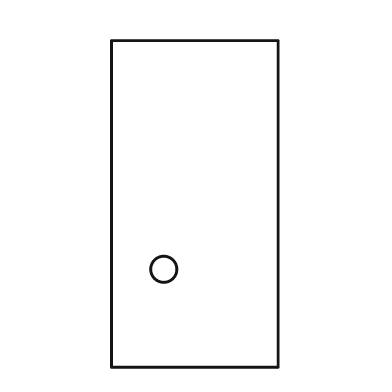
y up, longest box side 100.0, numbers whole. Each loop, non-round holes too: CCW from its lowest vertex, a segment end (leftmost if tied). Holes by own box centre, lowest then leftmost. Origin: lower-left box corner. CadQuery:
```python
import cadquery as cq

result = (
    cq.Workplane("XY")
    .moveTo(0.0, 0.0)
    .lineTo(51.0, 0.0)
    .lineTo(51.0, 100.0)
    .lineTo(0.0, 100.0)
    .close()
    .moveTo(16.0, 30.0)
    .circle(4.0)
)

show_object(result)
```